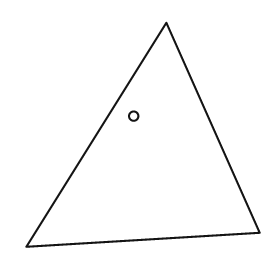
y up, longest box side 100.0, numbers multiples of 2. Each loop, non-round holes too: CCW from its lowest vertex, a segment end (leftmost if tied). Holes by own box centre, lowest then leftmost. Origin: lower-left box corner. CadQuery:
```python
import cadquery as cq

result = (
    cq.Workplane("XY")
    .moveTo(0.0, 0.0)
    .lineTo(100.0, 6.0)
    .lineTo(60.0, 96.0)
    .close()
    .moveTo(46.0, 56.0)
    .circle(2.0)
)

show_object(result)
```